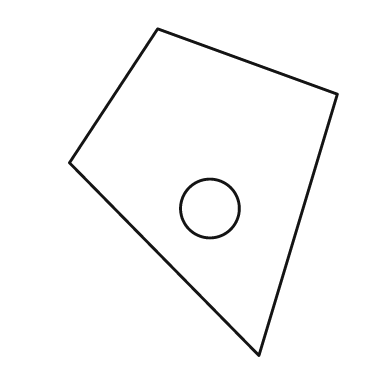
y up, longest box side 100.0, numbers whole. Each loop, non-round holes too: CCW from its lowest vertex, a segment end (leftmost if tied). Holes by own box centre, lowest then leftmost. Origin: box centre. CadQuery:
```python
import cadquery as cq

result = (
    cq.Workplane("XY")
    .moveTo(17.0, -50.0)
    .lineTo(41.0, 30.0)
    .lineTo(-14.0, 50.0)
    .lineTo(-41.0, 9.0)
    .close()
    .moveTo(2.0, -5.0)
    .circle(9.0)
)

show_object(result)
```